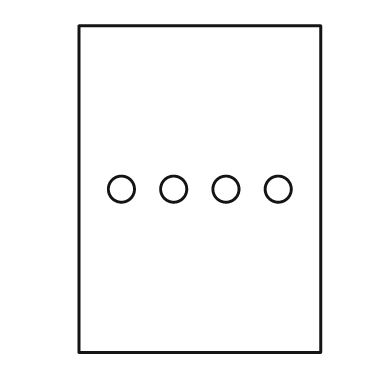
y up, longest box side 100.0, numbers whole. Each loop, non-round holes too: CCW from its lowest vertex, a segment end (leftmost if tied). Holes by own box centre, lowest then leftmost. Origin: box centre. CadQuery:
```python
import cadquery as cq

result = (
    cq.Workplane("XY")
    .moveTo(-37.0, -50.0)
    .lineTo(37.0, -50.0)
    .lineTo(37.0, 50.0)
    .lineTo(-37.0, 50.0)
    .close()
    .moveTo(-24.0, 0.0)
    .circle(4.0)
    .moveTo(-8.0, 0.0)
    .circle(4.0)
    .moveTo(8.0, 0.0)
    .circle(4.0)
    .moveTo(24.0, 0.0)
    .circle(4.0)
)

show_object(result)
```